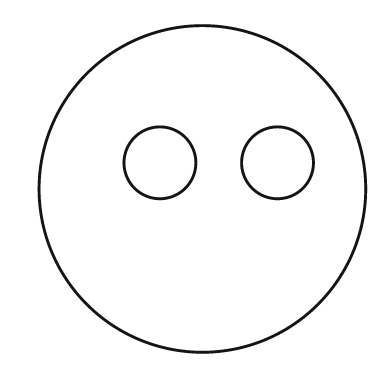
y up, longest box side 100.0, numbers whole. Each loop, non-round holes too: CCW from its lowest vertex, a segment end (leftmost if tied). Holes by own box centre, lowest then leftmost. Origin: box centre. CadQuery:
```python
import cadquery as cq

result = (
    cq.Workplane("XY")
    .moveTo(0.0, 0.0)
    .circle(50.0)
    .moveTo(-13.0, 8.0)
    .circle(11.0)
    .moveTo(23.0, 8.0)
    .circle(11.0)
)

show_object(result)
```